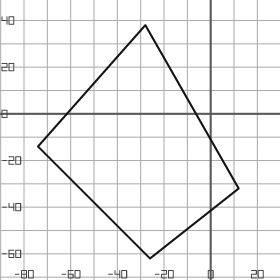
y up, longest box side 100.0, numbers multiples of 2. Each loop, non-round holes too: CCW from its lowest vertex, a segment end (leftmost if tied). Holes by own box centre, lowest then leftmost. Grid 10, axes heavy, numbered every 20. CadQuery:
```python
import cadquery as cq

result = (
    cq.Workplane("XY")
    .moveTo(-26.0, -62.0)
    .lineTo(12.0, -32.0)
    .lineTo(-28.0, 38.0)
    .lineTo(-74.0, -14.0)
    .close()
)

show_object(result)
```